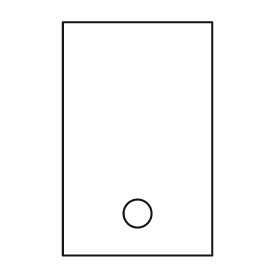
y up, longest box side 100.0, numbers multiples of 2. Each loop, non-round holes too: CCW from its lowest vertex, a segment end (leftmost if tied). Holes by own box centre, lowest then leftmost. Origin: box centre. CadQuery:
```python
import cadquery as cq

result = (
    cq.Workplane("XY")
    .moveTo(-32.0, -50.0)
    .lineTo(32.0, -50.0)
    .lineTo(32.0, 50.0)
    .lineTo(-32.0, 50.0)
    .close()
    .moveTo(0.0, -32.0)
    .circle(6.0)
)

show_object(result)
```